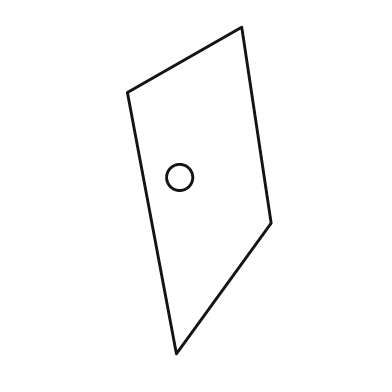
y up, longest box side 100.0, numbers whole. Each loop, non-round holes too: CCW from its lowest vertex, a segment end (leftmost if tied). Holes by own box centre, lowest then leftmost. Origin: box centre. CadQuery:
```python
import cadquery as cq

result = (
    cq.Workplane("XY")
    .moveTo(-7.0, -50.0)
    .lineTo(22.0, -10.0)
    .lineTo(13.0, 50.0)
    .lineTo(-22.0, 30.0)
    .close()
    .moveTo(-6.0, 4.0)
    .circle(4.0)
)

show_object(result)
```